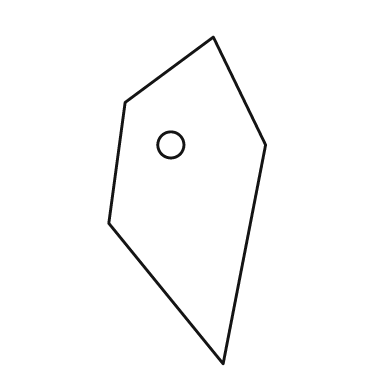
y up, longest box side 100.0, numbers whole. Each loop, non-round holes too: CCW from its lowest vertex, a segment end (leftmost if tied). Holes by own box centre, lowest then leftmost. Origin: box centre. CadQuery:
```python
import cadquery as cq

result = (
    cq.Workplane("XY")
    .moveTo(11.0, -50.0)
    .lineTo(24.0, 17.0)
    .lineTo(8.0, 50.0)
    .lineTo(-19.0, 30.0)
    .lineTo(-24.0, -7.0)
    .close()
    .moveTo(-5.0, 17.0)
    .circle(4.0)
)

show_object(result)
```